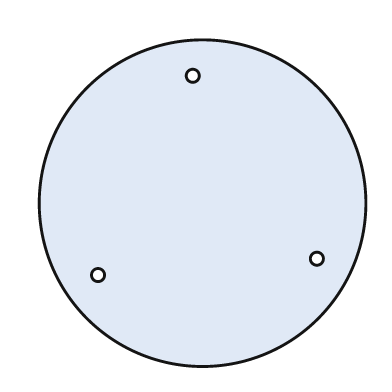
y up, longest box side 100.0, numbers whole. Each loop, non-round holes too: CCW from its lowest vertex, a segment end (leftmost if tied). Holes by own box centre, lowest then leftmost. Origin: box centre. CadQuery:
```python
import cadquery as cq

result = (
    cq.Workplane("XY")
    .moveTo(0.0, 0.0)
    .circle(50.0)
    .moveTo(-32.0, -22.0)
    .circle(2.0)
    .moveTo(35.0, -17.0)
    .circle(2.0)
    .moveTo(-3.0, 39.0)
    .circle(2.0)
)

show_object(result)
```